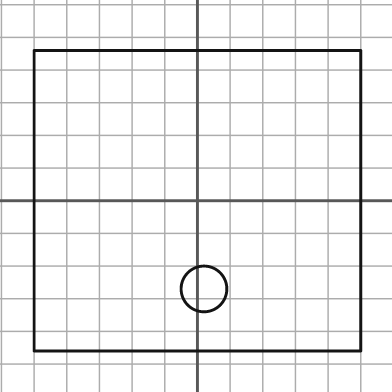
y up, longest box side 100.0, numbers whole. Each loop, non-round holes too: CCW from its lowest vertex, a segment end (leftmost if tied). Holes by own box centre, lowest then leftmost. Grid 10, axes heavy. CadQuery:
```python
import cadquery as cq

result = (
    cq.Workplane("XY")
    .moveTo(-50.0, -46.0)
    .lineTo(50.0, -46.0)
    .lineTo(50.0, 46.0)
    .lineTo(-50.0, 46.0)
    .close()
    .moveTo(2.0, -27.0)
    .circle(7.0)
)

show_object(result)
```